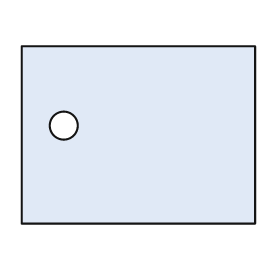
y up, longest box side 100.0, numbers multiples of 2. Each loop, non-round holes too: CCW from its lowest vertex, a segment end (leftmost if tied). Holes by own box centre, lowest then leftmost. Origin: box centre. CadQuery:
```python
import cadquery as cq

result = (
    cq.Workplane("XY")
    .moveTo(-50.0, -38.0)
    .lineTo(50.0, -38.0)
    .lineTo(50.0, 38.0)
    .lineTo(-50.0, 38.0)
    .close()
    .moveTo(-32.0, 4.0)
    .circle(6.0)
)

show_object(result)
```